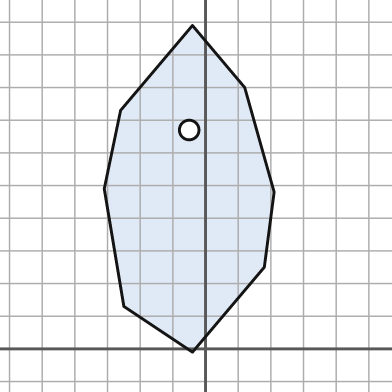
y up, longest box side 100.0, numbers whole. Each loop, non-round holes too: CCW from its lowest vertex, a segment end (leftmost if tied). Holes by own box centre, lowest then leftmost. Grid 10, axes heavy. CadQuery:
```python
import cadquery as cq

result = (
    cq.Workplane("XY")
    .moveTo(-4.0, -1.0)
    .lineTo(18.0, 25.0)
    .lineTo(21.0, 48.0)
    .lineTo(12.0, 80.0)
    .lineTo(-4.0, 99.0)
    .lineTo(-26.0, 73.0)
    .lineTo(-31.0, 49.0)
    .lineTo(-25.0, 13.0)
    .close()
    .moveTo(-5.0, 67.0)
    .circle(3.0)
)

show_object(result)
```